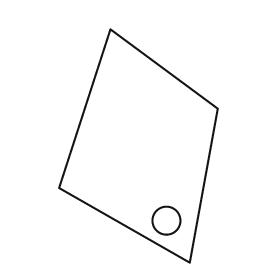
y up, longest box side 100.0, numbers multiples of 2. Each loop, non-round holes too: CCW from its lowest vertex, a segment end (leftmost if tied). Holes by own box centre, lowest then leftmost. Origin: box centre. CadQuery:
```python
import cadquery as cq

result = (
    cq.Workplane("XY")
    .moveTo(22.0, -50.0)
    .lineTo(34.0, 16.0)
    .lineTo(-12.0, 50.0)
    .lineTo(-34.0, -18.0)
    .close()
    .moveTo(12.0, -32.0)
    .circle(6.0)
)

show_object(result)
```